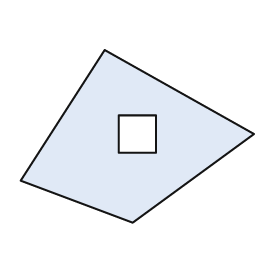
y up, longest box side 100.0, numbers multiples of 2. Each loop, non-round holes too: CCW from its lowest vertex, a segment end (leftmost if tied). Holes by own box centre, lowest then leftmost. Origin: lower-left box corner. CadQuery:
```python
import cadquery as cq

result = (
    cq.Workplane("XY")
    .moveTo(48.0, 0.0)
    .lineTo(100.0, 38.0)
    .lineTo(36.0, 74.0)
    .lineTo(0.0, 18.0)
    .close()
    .moveTo(42.0, 30.0)
    .lineTo(58.0, 30.0)
    .lineTo(58.0, 46.0)
    .lineTo(42.0, 46.0)
    .close()
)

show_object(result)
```